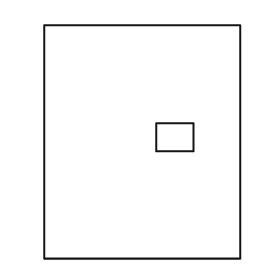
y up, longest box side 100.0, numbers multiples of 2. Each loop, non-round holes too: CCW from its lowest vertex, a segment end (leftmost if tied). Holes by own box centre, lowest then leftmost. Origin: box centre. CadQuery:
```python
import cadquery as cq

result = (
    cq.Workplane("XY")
    .moveTo(-42.0, -50.0)
    .lineTo(42.0, -50.0)
    .lineTo(42.0, 50.0)
    .lineTo(-42.0, 50.0)
    .close()
    .moveTo(6.0, -4.0)
    .lineTo(22.0, -4.0)
    .lineTo(22.0, 8.0)
    .lineTo(6.0, 8.0)
    .close()
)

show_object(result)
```